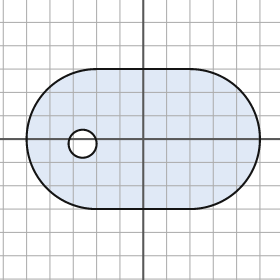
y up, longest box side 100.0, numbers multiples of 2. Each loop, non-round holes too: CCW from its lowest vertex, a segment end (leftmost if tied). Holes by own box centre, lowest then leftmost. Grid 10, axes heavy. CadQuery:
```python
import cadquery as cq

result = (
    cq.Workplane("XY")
    .moveTo(-20.0, -30.0)
    .lineTo(20.0, -30.0)
    .threePointArc((50.0, 0.0), (20.0, 30.0))
    .lineTo(-20.0, 30.0)
    .threePointArc((-50.0, 0.0), (-20.0, -30.0))
    .close()
    .moveTo(-26.0, -2.0)
    .circle(6.0)
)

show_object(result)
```